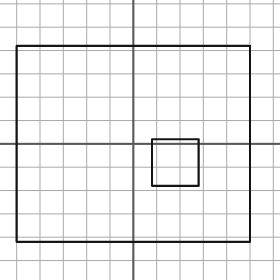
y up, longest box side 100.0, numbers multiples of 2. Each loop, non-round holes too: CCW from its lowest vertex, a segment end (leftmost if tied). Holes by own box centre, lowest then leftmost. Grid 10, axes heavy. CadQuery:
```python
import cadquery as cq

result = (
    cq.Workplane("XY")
    .moveTo(-50.0, -42.0)
    .lineTo(50.0, -42.0)
    .lineTo(50.0, 42.0)
    .lineTo(-50.0, 42.0)
    .close()
    .moveTo(8.0, -18.0)
    .lineTo(28.0, -18.0)
    .lineTo(28.0, 2.0)
    .lineTo(8.0, 2.0)
    .close()
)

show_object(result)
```